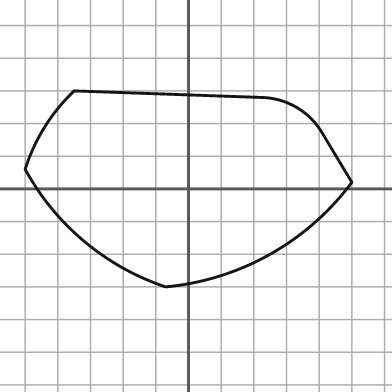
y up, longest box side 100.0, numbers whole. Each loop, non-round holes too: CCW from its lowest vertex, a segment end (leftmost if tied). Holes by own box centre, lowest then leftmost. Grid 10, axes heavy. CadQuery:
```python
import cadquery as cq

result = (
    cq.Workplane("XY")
    .moveTo(-7.0, -30.0)
    .threePointArc((25.0, -20.0), (50.0, 2.0))
    .lineTo(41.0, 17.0)
    .threePointArc((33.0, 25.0), (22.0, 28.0))
    .lineTo(-35.0, 30.0)
    .threePointArc((-44.0, 19.0), (-50.0, 6.0))
    .threePointArc((-32.0, -16.0), (-7.0, -30.0))
    .close()
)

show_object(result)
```